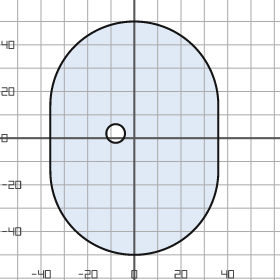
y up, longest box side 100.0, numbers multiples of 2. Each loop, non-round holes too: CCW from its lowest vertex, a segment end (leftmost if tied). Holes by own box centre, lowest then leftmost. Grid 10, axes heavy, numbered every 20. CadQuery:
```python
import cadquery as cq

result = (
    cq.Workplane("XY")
    .moveTo(-36.0, -14.0)
    .threePointArc((0.0, -50.0), (36.0, -14.0))
    .lineTo(36.0, 14.0)
    .threePointArc((0.0, 50.0), (-36.0, 14.0))
    .close()
    .moveTo(-8.0, 2.0)
    .circle(4.0)
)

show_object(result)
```